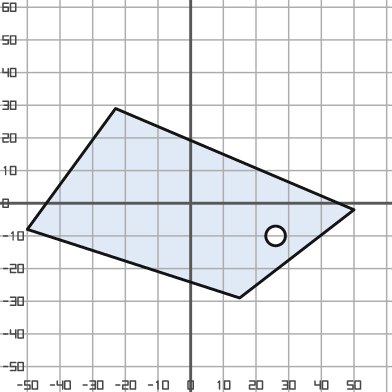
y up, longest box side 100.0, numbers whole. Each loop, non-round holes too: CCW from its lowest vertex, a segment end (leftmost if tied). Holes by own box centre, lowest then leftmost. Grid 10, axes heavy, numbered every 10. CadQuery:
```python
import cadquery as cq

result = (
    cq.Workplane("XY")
    .moveTo(15.0, -29.0)
    .lineTo(50.0, -2.0)
    .lineTo(-23.0, 29.0)
    .lineTo(-50.0, -8.0)
    .close()
    .moveTo(26.0, -10.0)
    .circle(3.0)
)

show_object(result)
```